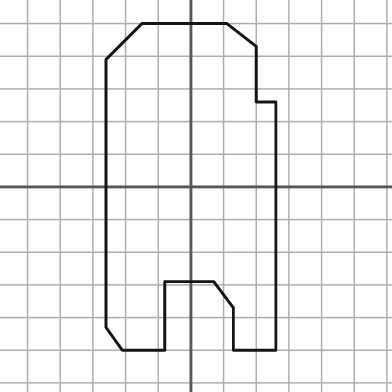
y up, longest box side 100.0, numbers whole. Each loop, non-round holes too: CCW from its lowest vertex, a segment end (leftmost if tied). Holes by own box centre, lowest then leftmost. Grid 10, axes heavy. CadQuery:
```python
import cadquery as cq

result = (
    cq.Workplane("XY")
    .moveTo(-21.0, -50.0)
    .lineTo(-8.0, -50.0)
    .lineTo(-8.0, -29.0)
    .lineTo(7.0, -29.0)
    .lineTo(13.0, -37.0)
    .lineTo(13.0, -50.0)
    .lineTo(26.0, -50.0)
    .lineTo(26.0, 26.0)
    .lineTo(20.0, 26.0)
    .lineTo(20.0, 43.0)
    .lineTo(11.0, 50.0)
    .lineTo(-15.0, 50.0)
    .lineTo(-26.0, 39.0)
    .lineTo(-26.0, -43.0)
    .close()
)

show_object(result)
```